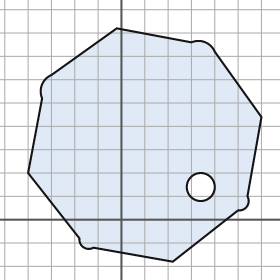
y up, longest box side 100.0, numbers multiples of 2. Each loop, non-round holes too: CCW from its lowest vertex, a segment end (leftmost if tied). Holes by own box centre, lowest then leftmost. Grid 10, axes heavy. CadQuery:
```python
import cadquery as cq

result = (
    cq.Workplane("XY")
    .moveTo(22.0, -18.0)
    .lineTo(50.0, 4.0)
    .threePointArc((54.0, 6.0), (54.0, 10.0))
    .lineTo(60.0, 44.0)
    .lineTo(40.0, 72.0)
    .threePointArc((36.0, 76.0), (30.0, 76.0))
    .lineTo(-2.0, 82.0)
    .lineTo(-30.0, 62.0)
    .threePointArc((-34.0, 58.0), (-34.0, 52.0))
    .lineTo(-40.0, 20.0)
    .lineTo(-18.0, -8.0)
    .threePointArc((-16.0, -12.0), (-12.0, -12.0))
    .close()
    .moveTo(34.0, 14.0)
    .circle(6.0)
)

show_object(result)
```